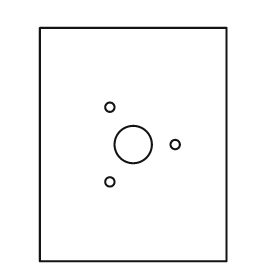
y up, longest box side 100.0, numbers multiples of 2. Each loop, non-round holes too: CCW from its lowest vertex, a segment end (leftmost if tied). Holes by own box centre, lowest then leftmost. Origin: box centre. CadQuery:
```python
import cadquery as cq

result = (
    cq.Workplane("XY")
    .moveTo(-40.0, -50.0)
    .lineTo(40.0, -50.0)
    .lineTo(40.0, 50.0)
    .lineTo(-40.0, 50.0)
    .close()
    .moveTo(-10.0, -16.0)
    .circle(2.0)
    .moveTo(0.0, 0.0)
    .circle(8.0)
    .moveTo(18.0, 0.0)
    .circle(2.0)
    .moveTo(-10.0, 16.0)
    .circle(2.0)
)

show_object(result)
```